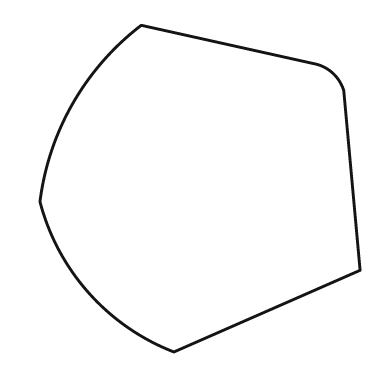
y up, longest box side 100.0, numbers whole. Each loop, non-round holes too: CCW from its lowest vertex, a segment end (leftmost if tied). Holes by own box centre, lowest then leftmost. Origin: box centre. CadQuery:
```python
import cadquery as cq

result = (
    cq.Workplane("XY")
    .moveTo(-8.0, -50.0)
    .lineTo(49.0, -25.0)
    .lineTo(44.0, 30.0)
    .threePointArc((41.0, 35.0), (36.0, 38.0))
    .lineTo(-18.0, 50.0)
    .threePointArc((-39.0, 26.0), (-49.0, -4.0))
    .threePointArc((-34.0, -32.0), (-8.0, -50.0))
    .close()
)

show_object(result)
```